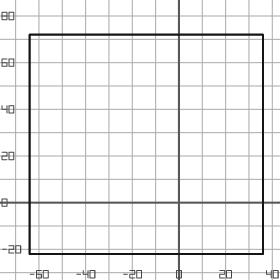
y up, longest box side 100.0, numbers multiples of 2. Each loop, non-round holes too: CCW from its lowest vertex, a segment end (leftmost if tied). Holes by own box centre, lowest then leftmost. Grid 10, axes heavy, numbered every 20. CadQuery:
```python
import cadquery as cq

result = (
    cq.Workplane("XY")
    .moveTo(-64.0, -22.0)
    .lineTo(36.0, -22.0)
    .lineTo(36.0, 72.0)
    .lineTo(-64.0, 72.0)
    .close()
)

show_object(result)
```